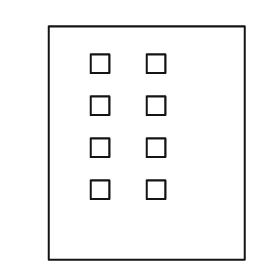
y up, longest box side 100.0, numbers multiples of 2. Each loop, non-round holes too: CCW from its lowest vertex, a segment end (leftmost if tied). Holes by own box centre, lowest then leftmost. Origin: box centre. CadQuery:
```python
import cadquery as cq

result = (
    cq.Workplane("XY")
    .moveTo(-42.0, -50.0)
    .lineTo(42.0, -50.0)
    .lineTo(42.0, 50.0)
    .lineTo(-42.0, 50.0)
    .close()
    .moveTo(-24.0, -24.0)
    .lineTo(-16.0, -24.0)
    .lineTo(-16.0, -16.0)
    .lineTo(-24.0, -16.0)
    .close()
    .moveTo(0.0, -24.0)
    .lineTo(8.0, -24.0)
    .lineTo(8.0, -16.0)
    .lineTo(0.0, -16.0)
    .close()
    .moveTo(-24.0, -6.0)
    .lineTo(-16.0, -6.0)
    .lineTo(-16.0, 2.0)
    .lineTo(-24.0, 2.0)
    .close()
    .moveTo(0.0, -6.0)
    .lineTo(8.0, -6.0)
    .lineTo(8.0, 2.0)
    .lineTo(0.0, 2.0)
    .close()
    .moveTo(-24.0, 12.0)
    .lineTo(-16.0, 12.0)
    .lineTo(-16.0, 20.0)
    .lineTo(-24.0, 20.0)
    .close()
    .moveTo(0.0, 12.0)
    .lineTo(8.0, 12.0)
    .lineTo(8.0, 20.0)
    .lineTo(0.0, 20.0)
    .close()
    .moveTo(-24.0, 30.0)
    .lineTo(-16.0, 30.0)
    .lineTo(-16.0, 38.0)
    .lineTo(-24.0, 38.0)
    .close()
    .moveTo(0.0, 30.0)
    .lineTo(8.0, 30.0)
    .lineTo(8.0, 38.0)
    .lineTo(0.0, 38.0)
    .close()
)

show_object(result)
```